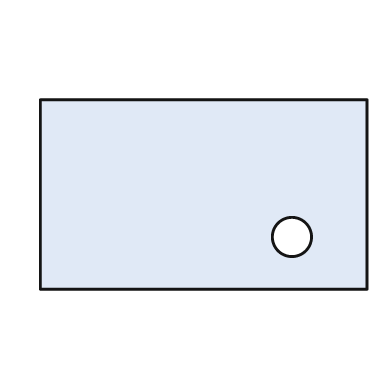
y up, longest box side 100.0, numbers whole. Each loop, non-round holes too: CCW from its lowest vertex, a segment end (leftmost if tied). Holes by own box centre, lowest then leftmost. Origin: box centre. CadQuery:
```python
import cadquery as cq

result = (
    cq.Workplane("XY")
    .moveTo(-50.0, -29.0)
    .lineTo(50.0, -29.0)
    .lineTo(50.0, 29.0)
    .lineTo(-50.0, 29.0)
    .close()
    .moveTo(27.0, -13.0)
    .circle(6.0)
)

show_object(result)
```